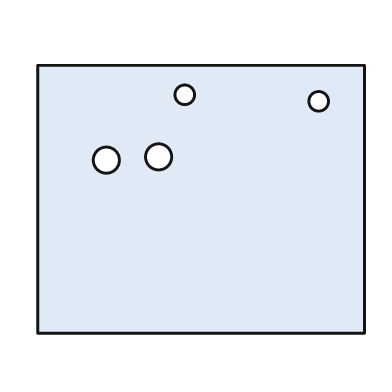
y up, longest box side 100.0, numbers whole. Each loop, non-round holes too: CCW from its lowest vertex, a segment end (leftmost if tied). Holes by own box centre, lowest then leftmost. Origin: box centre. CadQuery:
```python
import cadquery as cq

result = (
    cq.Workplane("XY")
    .moveTo(-50.0, -41.0)
    .lineTo(50.0, -41.0)
    .lineTo(50.0, 41.0)
    .lineTo(-50.0, 41.0)
    .close()
    .moveTo(-29.0, 12.0)
    .circle(4.0)
    .moveTo(-13.0, 13.0)
    .circle(4.0)
    .moveTo(36.0, 30.0)
    .circle(3.0)
    .moveTo(-5.0, 32.0)
    .circle(3.0)
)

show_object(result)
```